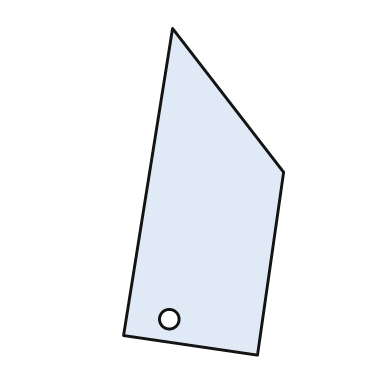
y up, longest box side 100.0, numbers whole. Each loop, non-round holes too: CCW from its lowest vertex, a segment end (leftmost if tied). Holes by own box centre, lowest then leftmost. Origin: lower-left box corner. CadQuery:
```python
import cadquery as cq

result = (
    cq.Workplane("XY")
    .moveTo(41.0, 0.0)
    .lineTo(49.0, 56.0)
    .lineTo(15.0, 100.0)
    .lineTo(0.0, 6.0)
    .close()
    .moveTo(14.0, 11.0)
    .circle(3.0)
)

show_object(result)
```